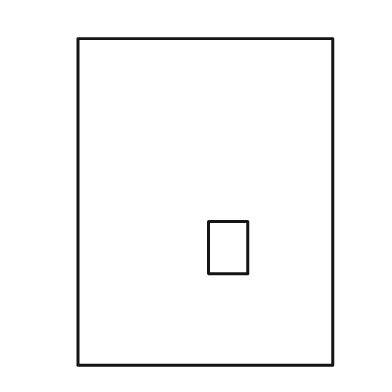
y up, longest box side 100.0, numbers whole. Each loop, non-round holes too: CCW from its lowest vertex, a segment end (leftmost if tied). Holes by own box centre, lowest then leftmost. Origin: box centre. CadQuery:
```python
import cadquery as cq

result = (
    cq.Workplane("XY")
    .moveTo(-39.0, -50.0)
    .lineTo(39.0, -50.0)
    .lineTo(39.0, 50.0)
    .lineTo(-39.0, 50.0)
    .close()
    .moveTo(1.0, -22.0)
    .lineTo(13.0, -22.0)
    .lineTo(13.0, -6.0)
    .lineTo(1.0, -6.0)
    .close()
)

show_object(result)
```